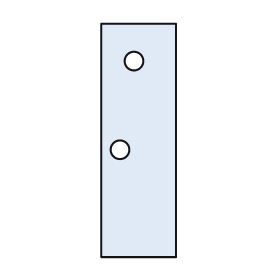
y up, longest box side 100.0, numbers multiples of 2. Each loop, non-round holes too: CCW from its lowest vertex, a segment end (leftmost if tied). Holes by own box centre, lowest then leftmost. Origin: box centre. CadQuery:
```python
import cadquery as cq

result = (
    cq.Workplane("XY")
    .moveTo(-16.0, -50.0)
    .lineTo(16.0, -50.0)
    .lineTo(16.0, 50.0)
    .lineTo(-16.0, 50.0)
    .close()
    .moveTo(-8.0, -4.0)
    .circle(4.0)
    .moveTo(-2.0, 34.0)
    .circle(4.0)
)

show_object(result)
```